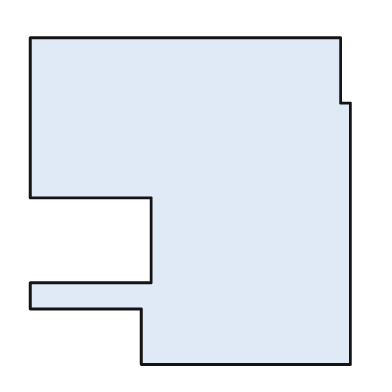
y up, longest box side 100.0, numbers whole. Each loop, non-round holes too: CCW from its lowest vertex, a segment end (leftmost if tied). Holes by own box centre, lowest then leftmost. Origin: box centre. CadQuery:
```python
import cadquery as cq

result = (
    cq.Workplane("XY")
    .moveTo(-15.0, -50.0)
    .lineTo(49.0, -50.0)
    .lineTo(49.0, 30.0)
    .lineTo(46.0, 30.0)
    .lineTo(46.0, 50.0)
    .lineTo(-49.0, 50.0)
    .lineTo(-49.0, 1.0)
    .lineTo(-12.0, 1.0)
    .lineTo(-12.0, -25.0)
    .lineTo(-49.0, -25.0)
    .lineTo(-49.0, -33.0)
    .lineTo(-15.0, -33.0)
    .close()
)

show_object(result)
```